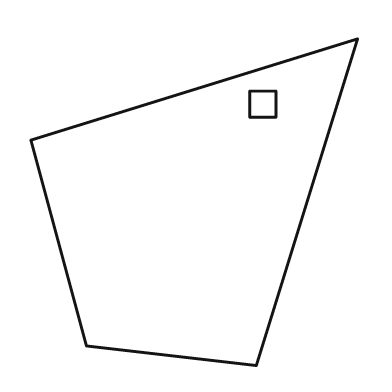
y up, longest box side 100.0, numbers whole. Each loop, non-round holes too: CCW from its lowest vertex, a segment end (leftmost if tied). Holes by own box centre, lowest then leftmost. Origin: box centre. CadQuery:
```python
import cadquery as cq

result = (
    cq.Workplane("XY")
    .moveTo(19.0, -50.0)
    .lineTo(50.0, 50.0)
    .lineTo(-50.0, 19.0)
    .lineTo(-33.0, -44.0)
    .close()
    .moveTo(17.0, 26.0)
    .lineTo(25.0, 26.0)
    .lineTo(25.0, 34.0)
    .lineTo(17.0, 34.0)
    .close()
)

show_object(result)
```